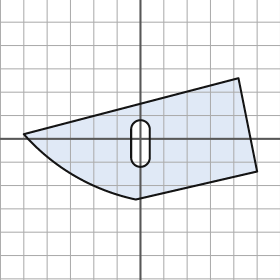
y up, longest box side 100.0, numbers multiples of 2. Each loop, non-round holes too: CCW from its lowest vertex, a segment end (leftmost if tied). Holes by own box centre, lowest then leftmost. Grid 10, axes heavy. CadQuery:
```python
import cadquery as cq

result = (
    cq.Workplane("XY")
    .moveTo(-2.0, -26.0)
    .lineTo(50.0, -14.0)
    .lineTo(42.0, 26.0)
    .lineTo(-50.0, 2.0)
    .threePointArc((-28.0, -16.0), (-2.0, -26.0))
    .close()
    .moveTo(-4.0, -8.0)
    .threePointArc((0.0, -12.0), (4.0, -8.0))
    .lineTo(4.0, 4.0)
    .threePointArc((0.0, 8.0), (-4.0, 4.0))
    .close()
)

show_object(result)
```